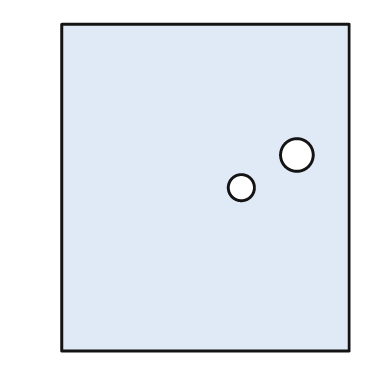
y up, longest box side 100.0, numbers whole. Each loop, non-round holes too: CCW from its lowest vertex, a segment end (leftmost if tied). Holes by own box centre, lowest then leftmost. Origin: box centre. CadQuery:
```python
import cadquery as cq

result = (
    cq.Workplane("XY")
    .moveTo(-44.0, -50.0)
    .lineTo(44.0, -50.0)
    .lineTo(44.0, 50.0)
    .lineTo(-44.0, 50.0)
    .close()
    .moveTo(11.0, 0.0)
    .circle(4.0)
    .moveTo(28.0, 10.0)
    .circle(5.0)
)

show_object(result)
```